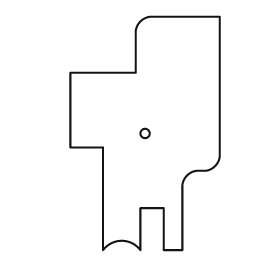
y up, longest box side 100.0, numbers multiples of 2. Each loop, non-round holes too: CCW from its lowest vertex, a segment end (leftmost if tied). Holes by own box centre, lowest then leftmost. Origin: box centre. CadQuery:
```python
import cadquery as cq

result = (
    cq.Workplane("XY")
    .moveTo(-18.0, -50.0)
    .threePointArc((-10.0, -46.0), (-2.0, -50.0))
    .lineTo(-2.0, -32.0)
    .lineTo(8.0, -32.0)
    .lineTo(8.0, -50.0)
    .lineTo(16.0, -50.0)
    .lineTo(16.0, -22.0)
    .threePointArc((18.0, -18.0), (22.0, -16.0))
    .lineTo(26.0, -16.0)
    .threePointArc((30.0, -14.0), (32.0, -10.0))
    .lineTo(32.0, 50.0)
    .lineTo(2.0, 50.0)
    .threePointArc((-2.0, 48.0), (-4.0, 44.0))
    .lineTo(-4.0, 26.0)
    .lineTo(-32.0, 26.0)
    .lineTo(-32.0, -6.0)
    .lineTo(-18.0, -6.0)
    .close()
    .moveTo(0.0, 0.0)
    .circle(2.0)
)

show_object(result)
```